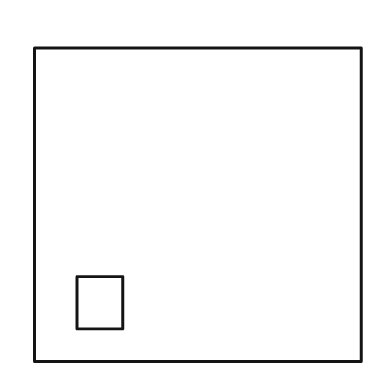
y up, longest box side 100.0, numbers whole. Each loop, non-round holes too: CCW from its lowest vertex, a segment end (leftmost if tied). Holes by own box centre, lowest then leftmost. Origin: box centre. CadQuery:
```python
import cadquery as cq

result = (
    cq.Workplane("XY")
    .moveTo(-50.0, -48.0)
    .lineTo(50.0, -48.0)
    .lineTo(50.0, 48.0)
    .lineTo(-50.0, 48.0)
    .close()
    .moveTo(-37.0, -38.0)
    .lineTo(-23.0, -38.0)
    .lineTo(-23.0, -22.0)
    .lineTo(-37.0, -22.0)
    .close()
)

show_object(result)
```